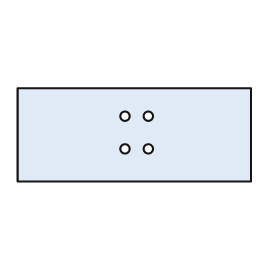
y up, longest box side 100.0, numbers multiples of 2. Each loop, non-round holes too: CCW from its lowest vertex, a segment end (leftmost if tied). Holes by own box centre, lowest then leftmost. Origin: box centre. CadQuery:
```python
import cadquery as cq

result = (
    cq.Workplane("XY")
    .moveTo(-50.0, -20.0)
    .lineTo(50.0, -20.0)
    .lineTo(50.0, 20.0)
    .lineTo(-50.0, 20.0)
    .close()
    .moveTo(-4.0, -6.0)
    .circle(2.0)
    .moveTo(6.0, -6.0)
    .circle(2.0)
    .moveTo(-4.0, 8.0)
    .circle(2.0)
    .moveTo(6.0, 8.0)
    .circle(2.0)
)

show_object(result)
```